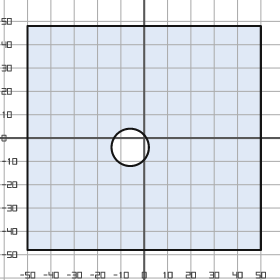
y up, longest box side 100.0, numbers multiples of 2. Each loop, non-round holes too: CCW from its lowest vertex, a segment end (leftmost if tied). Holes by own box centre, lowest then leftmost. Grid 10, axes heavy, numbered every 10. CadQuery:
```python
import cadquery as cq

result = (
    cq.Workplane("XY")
    .moveTo(-50.0, -48.0)
    .lineTo(50.0, -48.0)
    .lineTo(50.0, 48.0)
    .lineTo(-50.0, 48.0)
    .close()
    .moveTo(-6.0, -4.0)
    .circle(8.0)
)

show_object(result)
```